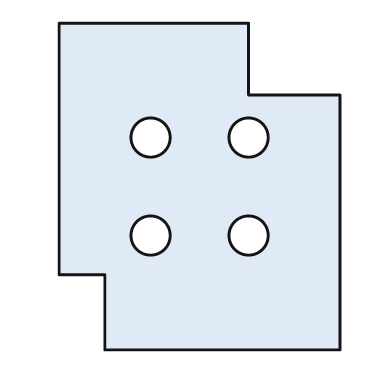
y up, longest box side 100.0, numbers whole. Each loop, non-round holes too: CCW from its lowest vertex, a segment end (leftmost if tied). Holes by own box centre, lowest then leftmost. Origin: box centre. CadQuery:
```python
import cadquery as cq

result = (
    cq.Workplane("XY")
    .moveTo(-29.0, -50.0)
    .lineTo(43.0, -50.0)
    .lineTo(43.0, 28.0)
    .lineTo(15.0, 28.0)
    .lineTo(15.0, 50.0)
    .lineTo(-43.0, 50.0)
    .lineTo(-43.0, -27.0)
    .lineTo(-29.0, -27.0)
    .close()
    .moveTo(-15.0, -15.0)
    .circle(6.0)
    .moveTo(15.0, -15.0)
    .circle(6.0)
    .moveTo(-15.0, 15.0)
    .circle(6.0)
    .moveTo(15.0, 15.0)
    .circle(6.0)
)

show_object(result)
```